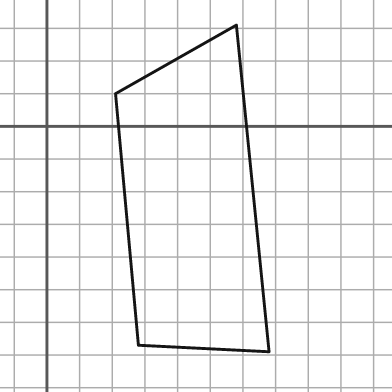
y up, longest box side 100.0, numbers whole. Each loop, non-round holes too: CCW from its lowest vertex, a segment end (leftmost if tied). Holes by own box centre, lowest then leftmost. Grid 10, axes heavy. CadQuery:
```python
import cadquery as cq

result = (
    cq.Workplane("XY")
    .moveTo(68.0, -69.0)
    .lineTo(58.0, 31.0)
    .lineTo(21.0, 10.0)
    .lineTo(28.0, -67.0)
    .close()
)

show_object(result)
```